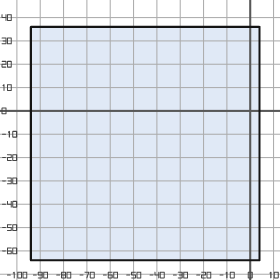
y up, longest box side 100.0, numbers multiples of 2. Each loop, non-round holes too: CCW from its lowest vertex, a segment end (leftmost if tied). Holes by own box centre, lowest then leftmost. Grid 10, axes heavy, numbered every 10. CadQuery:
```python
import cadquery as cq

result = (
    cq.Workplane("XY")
    .moveTo(-94.0, -64.0)
    .lineTo(4.0, -64.0)
    .lineTo(4.0, 36.0)
    .lineTo(-94.0, 36.0)
    .close()
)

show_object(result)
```